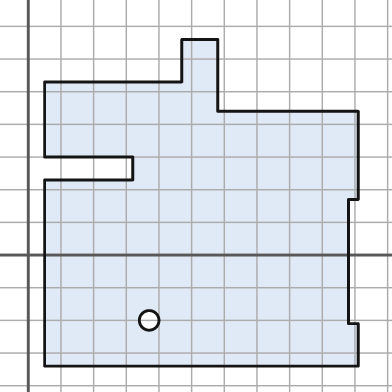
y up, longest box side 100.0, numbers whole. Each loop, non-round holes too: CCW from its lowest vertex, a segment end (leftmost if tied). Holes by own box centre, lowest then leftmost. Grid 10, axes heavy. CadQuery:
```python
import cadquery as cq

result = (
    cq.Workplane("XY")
    .moveTo(5.0, -34.0)
    .lineTo(101.0, -34.0)
    .lineTo(101.0, -21.0)
    .lineTo(98.0, -21.0)
    .lineTo(98.0, 17.0)
    .lineTo(101.0, 17.0)
    .lineTo(101.0, 44.0)
    .lineTo(58.0, 44.0)
    .lineTo(58.0, 66.0)
    .lineTo(47.0, 66.0)
    .lineTo(47.0, 53.0)
    .lineTo(5.0, 53.0)
    .lineTo(5.0, 30.0)
    .lineTo(32.0, 30.0)
    .lineTo(32.0, 23.0)
    .lineTo(5.0, 23.0)
    .close()
    .moveTo(37.0, -20.0)
    .circle(3.0)
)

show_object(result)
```